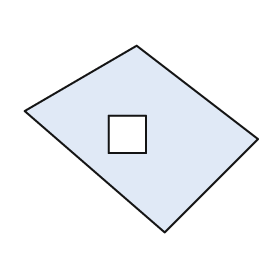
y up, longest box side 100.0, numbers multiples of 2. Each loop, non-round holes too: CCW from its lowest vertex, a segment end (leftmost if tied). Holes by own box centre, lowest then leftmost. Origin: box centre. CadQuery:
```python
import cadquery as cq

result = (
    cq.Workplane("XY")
    .moveTo(10.0, -40.0)
    .lineTo(50.0, 0.0)
    .lineTo(-2.0, 40.0)
    .lineTo(-50.0, 12.0)
    .close()
    .moveTo(-14.0, -6.0)
    .lineTo(2.0, -6.0)
    .lineTo(2.0, 10.0)
    .lineTo(-14.0, 10.0)
    .close()
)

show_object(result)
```